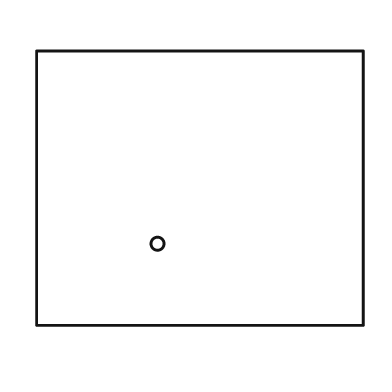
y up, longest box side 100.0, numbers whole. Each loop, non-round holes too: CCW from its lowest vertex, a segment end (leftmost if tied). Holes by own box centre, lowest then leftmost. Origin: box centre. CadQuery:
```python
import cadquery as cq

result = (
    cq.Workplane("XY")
    .moveTo(-50.0, -42.0)
    .lineTo(50.0, -42.0)
    .lineTo(50.0, 42.0)
    .lineTo(-50.0, 42.0)
    .close()
    .moveTo(-13.0, -17.0)
    .circle(2.0)
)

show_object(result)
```